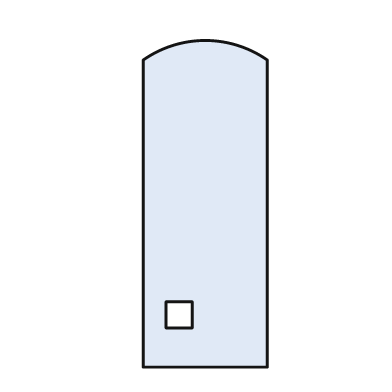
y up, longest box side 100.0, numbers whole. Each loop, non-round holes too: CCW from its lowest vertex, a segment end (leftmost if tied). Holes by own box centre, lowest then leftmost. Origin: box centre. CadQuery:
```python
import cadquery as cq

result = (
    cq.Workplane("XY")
    .moveTo(-19.0, -50.0)
    .lineTo(19.0, -50.0)
    .lineTo(19.0, 44.0)
    .threePointArc((0.0, 50.0), (-19.0, 44.0))
    .close()
    .moveTo(-12.0, -38.0)
    .lineTo(-4.0, -38.0)
    .lineTo(-4.0, -30.0)
    .lineTo(-12.0, -30.0)
    .close()
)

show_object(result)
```